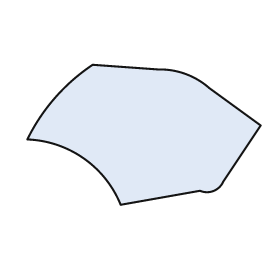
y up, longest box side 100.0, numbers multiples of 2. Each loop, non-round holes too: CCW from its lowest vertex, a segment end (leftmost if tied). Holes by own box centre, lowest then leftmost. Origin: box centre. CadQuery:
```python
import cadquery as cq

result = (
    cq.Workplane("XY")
    .moveTo(-10.0, -30.0)
    .lineTo(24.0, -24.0)
    .threePointArc((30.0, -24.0), (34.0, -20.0))
    .lineTo(50.0, 4.0)
    .lineTo(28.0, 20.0)
    .threePointArc((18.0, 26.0), (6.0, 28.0))
    .lineTo(-22.0, 30.0)
    .threePointArc((-38.0, 16.0), (-50.0, -2.0))
    .threePointArc((-26.0, -10.0), (-10.0, -30.0))
    .close()
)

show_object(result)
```